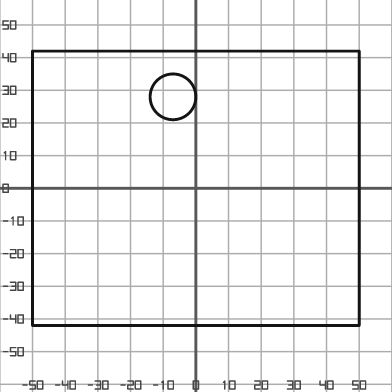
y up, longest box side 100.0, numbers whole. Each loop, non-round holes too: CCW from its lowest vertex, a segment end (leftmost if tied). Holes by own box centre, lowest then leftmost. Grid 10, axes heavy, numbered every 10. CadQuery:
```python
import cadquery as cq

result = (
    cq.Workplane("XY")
    .moveTo(-50.0, -42.0)
    .lineTo(50.0, -42.0)
    .lineTo(50.0, 42.0)
    .lineTo(-50.0, 42.0)
    .close()
    .moveTo(-7.0, 28.0)
    .circle(7.0)
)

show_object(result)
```